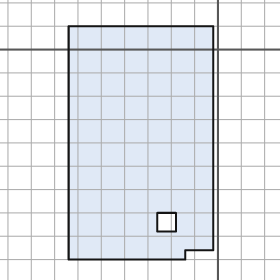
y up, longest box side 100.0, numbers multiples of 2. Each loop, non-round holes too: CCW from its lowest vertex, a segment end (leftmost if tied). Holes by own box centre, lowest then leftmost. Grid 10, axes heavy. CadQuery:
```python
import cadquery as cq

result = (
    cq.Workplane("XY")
    .moveTo(-64.0, -90.0)
    .lineTo(-14.0, -90.0)
    .lineTo(-14.0, -86.0)
    .lineTo(-2.0, -86.0)
    .lineTo(-2.0, 10.0)
    .lineTo(-64.0, 10.0)
    .close()
    .moveTo(-26.0, -78.0)
    .lineTo(-18.0, -78.0)
    .lineTo(-18.0, -70.0)
    .lineTo(-26.0, -70.0)
    .close()
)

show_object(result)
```